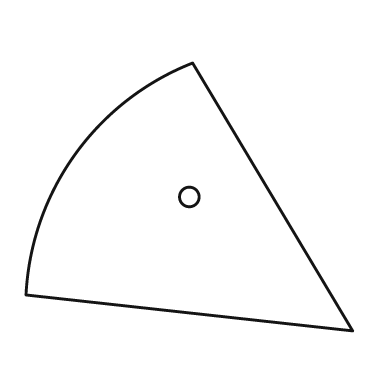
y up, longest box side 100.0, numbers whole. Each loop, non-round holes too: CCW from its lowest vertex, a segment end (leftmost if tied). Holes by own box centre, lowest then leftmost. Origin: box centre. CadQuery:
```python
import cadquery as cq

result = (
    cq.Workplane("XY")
    .moveTo(50.0, -41.0)
    .lineTo(1.0, 41.0)
    .threePointArc((-35.0, 13.0), (-50.0, -30.0))
    .close()
    .moveTo(0.0, 0.0)
    .circle(3.0)
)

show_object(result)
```